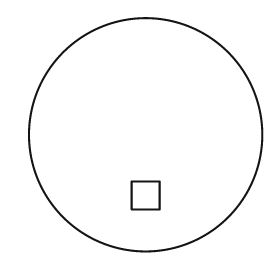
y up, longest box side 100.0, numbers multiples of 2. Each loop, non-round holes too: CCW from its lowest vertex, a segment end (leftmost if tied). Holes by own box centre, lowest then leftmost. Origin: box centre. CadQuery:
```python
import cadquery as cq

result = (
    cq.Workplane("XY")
    .moveTo(0.0, 0.0)
    .circle(50.0)
    .moveTo(-6.0, -32.0)
    .lineTo(6.0, -32.0)
    .lineTo(6.0, -20.0)
    .lineTo(-6.0, -20.0)
    .close()
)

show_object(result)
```